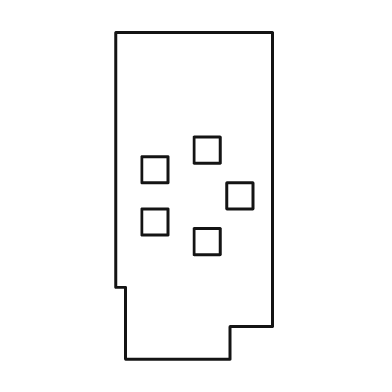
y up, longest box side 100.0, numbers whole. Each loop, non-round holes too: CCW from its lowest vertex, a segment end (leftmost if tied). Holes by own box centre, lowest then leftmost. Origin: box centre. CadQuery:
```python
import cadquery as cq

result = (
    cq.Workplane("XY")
    .moveTo(-21.0, -50.0)
    .lineTo(11.0, -50.0)
    .lineTo(11.0, -40.0)
    .lineTo(24.0, -40.0)
    .lineTo(24.0, 50.0)
    .lineTo(-24.0, 50.0)
    .lineTo(-24.0, -28.0)
    .lineTo(-21.0, -28.0)
    .close()
    .moveTo(0.0, -18.0)
    .lineTo(8.0, -18.0)
    .lineTo(8.0, -10.0)
    .lineTo(0.0, -10.0)
    .close()
    .moveTo(-16.0, -12.0)
    .lineTo(-8.0, -12.0)
    .lineTo(-8.0, -4.0)
    .lineTo(-16.0, -4.0)
    .close()
    .moveTo(10.0, -4.0)
    .lineTo(18.0, -4.0)
    .lineTo(18.0, 4.0)
    .lineTo(10.0, 4.0)
    .close()
    .moveTo(-16.0, 4.0)
    .lineTo(-8.0, 4.0)
    .lineTo(-8.0, 12.0)
    .lineTo(-16.0, 12.0)
    .close()
    .moveTo(0.0, 10.0)
    .lineTo(8.0, 10.0)
    .lineTo(8.0, 18.0)
    .lineTo(0.0, 18.0)
    .close()
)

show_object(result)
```